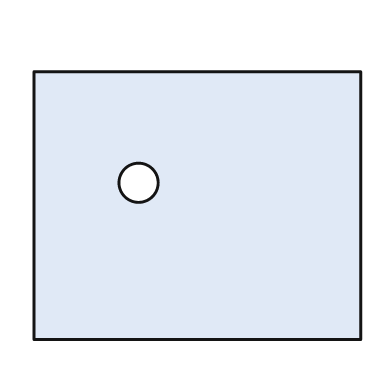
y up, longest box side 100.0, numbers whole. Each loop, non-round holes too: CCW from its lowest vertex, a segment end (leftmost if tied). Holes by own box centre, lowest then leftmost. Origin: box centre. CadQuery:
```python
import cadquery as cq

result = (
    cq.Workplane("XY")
    .moveTo(-50.0, -41.0)
    .lineTo(50.0, -41.0)
    .lineTo(50.0, 41.0)
    .lineTo(-50.0, 41.0)
    .close()
    .moveTo(-18.0, 7.0)
    .circle(6.0)
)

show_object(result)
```